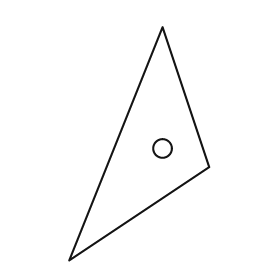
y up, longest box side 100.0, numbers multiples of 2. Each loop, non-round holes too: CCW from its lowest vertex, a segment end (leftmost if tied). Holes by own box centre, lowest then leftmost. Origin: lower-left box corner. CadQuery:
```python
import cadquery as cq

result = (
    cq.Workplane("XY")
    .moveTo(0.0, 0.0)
    .lineTo(60.0, 40.0)
    .lineTo(40.0, 100.0)
    .close()
    .moveTo(40.0, 48.0)
    .circle(4.0)
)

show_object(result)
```